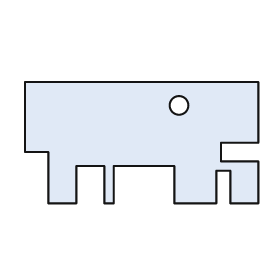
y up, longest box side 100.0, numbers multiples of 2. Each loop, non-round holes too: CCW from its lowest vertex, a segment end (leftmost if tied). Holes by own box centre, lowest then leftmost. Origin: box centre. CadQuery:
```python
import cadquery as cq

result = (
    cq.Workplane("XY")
    .moveTo(-40.0, -26.0)
    .lineTo(-28.0, -26.0)
    .lineTo(-28.0, -10.0)
    .lineTo(-16.0, -10.0)
    .lineTo(-16.0, -26.0)
    .lineTo(-12.0, -26.0)
    .lineTo(-12.0, -10.0)
    .lineTo(14.0, -10.0)
    .lineTo(14.0, -26.0)
    .lineTo(32.0, -26.0)
    .lineTo(32.0, -12.0)
    .lineTo(38.0, -12.0)
    .lineTo(38.0, -26.0)
    .lineTo(50.0, -26.0)
    .lineTo(50.0, -8.0)
    .lineTo(34.0, -8.0)
    .lineTo(34.0, 0.0)
    .lineTo(50.0, 0.0)
    .lineTo(50.0, 26.0)
    .lineTo(-50.0, 26.0)
    .lineTo(-50.0, -4.0)
    .lineTo(-40.0, -4.0)
    .close()
    .moveTo(16.0, 16.0)
    .circle(4.0)
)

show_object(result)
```